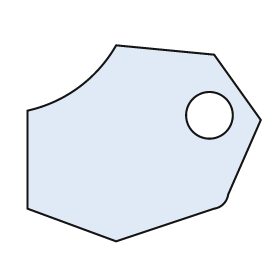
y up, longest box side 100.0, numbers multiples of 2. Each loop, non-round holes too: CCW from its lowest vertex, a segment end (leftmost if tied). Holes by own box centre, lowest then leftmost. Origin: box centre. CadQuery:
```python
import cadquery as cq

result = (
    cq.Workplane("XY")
    .moveTo(-12.0, -42.0)
    .lineTo(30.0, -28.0)
    .threePointArc((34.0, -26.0), (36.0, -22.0))
    .lineTo(50.0, 10.0)
    .lineTo(30.0, 38.0)
    .lineTo(-12.0, 42.0)
    .threePointArc((-28.0, 24.0), (-50.0, 14.0))
    .lineTo(-50.0, -28.0)
    .close()
    .moveTo(28.0, 12.0)
    .circle(10.0)
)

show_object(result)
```